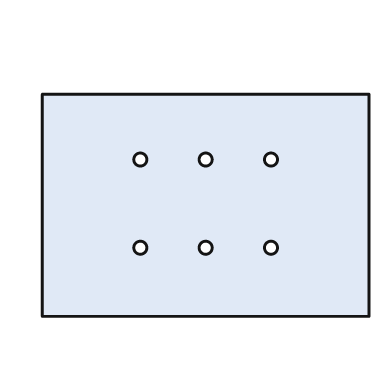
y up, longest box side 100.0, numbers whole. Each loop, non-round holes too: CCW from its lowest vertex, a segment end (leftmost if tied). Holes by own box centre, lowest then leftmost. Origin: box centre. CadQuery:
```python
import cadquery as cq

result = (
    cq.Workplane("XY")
    .moveTo(-50.0, -34.0)
    .lineTo(50.0, -34.0)
    .lineTo(50.0, 34.0)
    .lineTo(-50.0, 34.0)
    .close()
    .moveTo(-20.0, -13.0)
    .circle(2.0)
    .moveTo(0.0, -13.0)
    .circle(2.0)
    .moveTo(20.0, -13.0)
    .circle(2.0)
    .moveTo(-20.0, 14.0)
    .circle(2.0)
    .moveTo(0.0, 14.0)
    .circle(2.0)
    .moveTo(20.0, 14.0)
    .circle(2.0)
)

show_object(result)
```